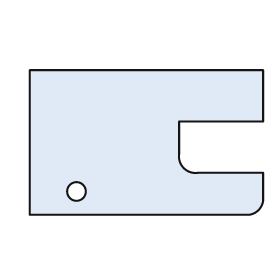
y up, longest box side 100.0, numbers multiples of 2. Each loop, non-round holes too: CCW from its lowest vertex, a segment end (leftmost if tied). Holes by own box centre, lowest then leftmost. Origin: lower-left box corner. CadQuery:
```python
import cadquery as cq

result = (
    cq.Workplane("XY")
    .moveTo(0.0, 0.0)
    .lineTo(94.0, 0.0)
    .threePointArc((98.0, 2.0), (100.0, 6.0))
    .lineTo(100.0, 18.0)
    .lineTo(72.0, 18.0)
    .threePointArc((66.0, 20.0), (64.0, 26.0))
    .lineTo(64.0, 40.0)
    .lineTo(100.0, 40.0)
    .lineTo(100.0, 62.0)
    .lineTo(0.0, 62.0)
    .close()
    .moveTo(20.0, 10.0)
    .circle(4.0)
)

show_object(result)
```